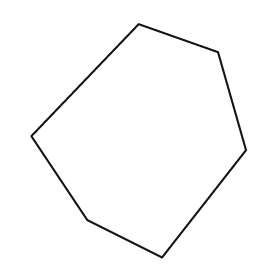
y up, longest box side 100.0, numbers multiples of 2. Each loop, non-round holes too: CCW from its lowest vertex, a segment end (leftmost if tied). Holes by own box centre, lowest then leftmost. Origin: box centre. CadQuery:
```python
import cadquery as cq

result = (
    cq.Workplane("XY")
    .moveTo(10.0, -50.0)
    .lineTo(46.0, -4.0)
    .lineTo(34.0, 38.0)
    .lineTo(0.0, 50.0)
    .lineTo(-46.0, 2.0)
    .lineTo(-22.0, -34.0)
    .close()
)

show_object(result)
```